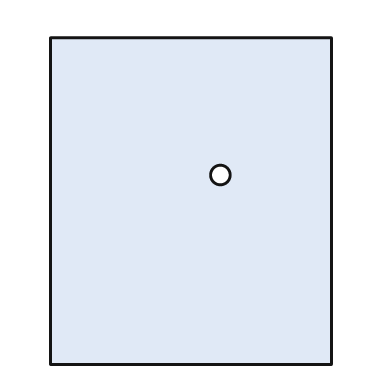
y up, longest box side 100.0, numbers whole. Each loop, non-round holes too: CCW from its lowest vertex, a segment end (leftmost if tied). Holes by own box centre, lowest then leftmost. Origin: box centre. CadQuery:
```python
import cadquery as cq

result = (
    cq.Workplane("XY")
    .moveTo(-43.0, -50.0)
    .lineTo(43.0, -50.0)
    .lineTo(43.0, 50.0)
    .lineTo(-43.0, 50.0)
    .close()
    .moveTo(9.0, 8.0)
    .circle(3.0)
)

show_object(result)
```